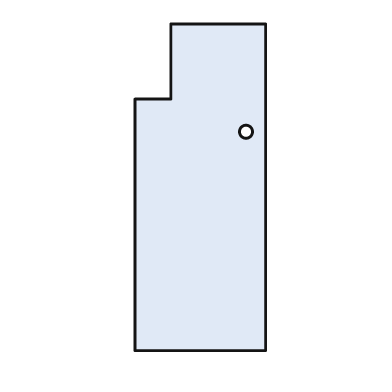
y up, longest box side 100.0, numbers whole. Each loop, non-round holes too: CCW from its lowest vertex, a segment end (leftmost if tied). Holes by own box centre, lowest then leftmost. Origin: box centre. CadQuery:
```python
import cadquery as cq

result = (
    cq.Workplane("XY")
    .moveTo(-20.0, -50.0)
    .lineTo(20.0, -50.0)
    .lineTo(20.0, 50.0)
    .lineTo(-9.0, 50.0)
    .lineTo(-9.0, 27.0)
    .lineTo(-20.0, 27.0)
    .close()
    .moveTo(14.0, 17.0)
    .circle(2.0)
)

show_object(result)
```